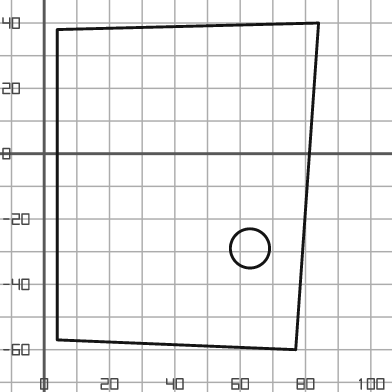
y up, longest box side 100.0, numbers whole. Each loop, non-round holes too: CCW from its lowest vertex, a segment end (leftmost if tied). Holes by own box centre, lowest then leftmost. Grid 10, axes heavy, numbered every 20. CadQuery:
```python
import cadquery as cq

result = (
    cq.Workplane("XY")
    .moveTo(77.0, -60.0)
    .lineTo(84.0, 40.0)
    .lineTo(4.0, 38.0)
    .lineTo(4.0, -57.0)
    .close()
    .moveTo(63.0, -29.0)
    .circle(6.0)
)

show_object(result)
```